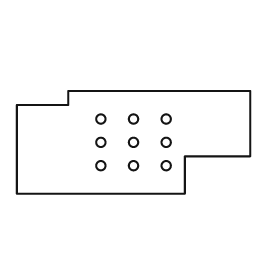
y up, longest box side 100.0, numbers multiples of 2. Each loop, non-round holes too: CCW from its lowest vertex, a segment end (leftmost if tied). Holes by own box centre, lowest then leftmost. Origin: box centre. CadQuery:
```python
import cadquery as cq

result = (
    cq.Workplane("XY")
    .moveTo(-50.0, -22.0)
    .lineTo(22.0, -22.0)
    .lineTo(22.0, -6.0)
    .lineTo(50.0, -6.0)
    .lineTo(50.0, 22.0)
    .lineTo(-28.0, 22.0)
    .lineTo(-28.0, 16.0)
    .lineTo(-50.0, 16.0)
    .close()
    .moveTo(-14.0, -10.0)
    .circle(2.0)
    .moveTo(0.0, -10.0)
    .circle(2.0)
    .moveTo(14.0, -10.0)
    .circle(2.0)
    .moveTo(-14.0, 0.0)
    .circle(2.0)
    .moveTo(0.0, 0.0)
    .circle(2.0)
    .moveTo(14.0, 0.0)
    .circle(2.0)
    .moveTo(-14.0, 10.0)
    .circle(2.0)
    .moveTo(0.0, 10.0)
    .circle(2.0)
    .moveTo(14.0, 10.0)
    .circle(2.0)
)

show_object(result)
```